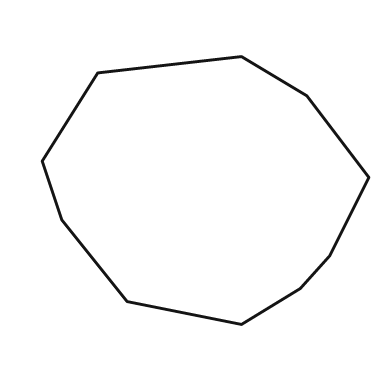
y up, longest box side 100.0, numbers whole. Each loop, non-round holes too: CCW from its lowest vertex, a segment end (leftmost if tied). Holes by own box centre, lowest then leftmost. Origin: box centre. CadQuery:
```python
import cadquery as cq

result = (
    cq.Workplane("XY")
    .moveTo(11.0, -41.0)
    .lineTo(29.0, -30.0)
    .lineTo(38.0, -20.0)
    .lineTo(50.0, 4.0)
    .lineTo(31.0, 29.0)
    .lineTo(11.0, 41.0)
    .lineTo(-33.0, 36.0)
    .lineTo(-50.0, 9.0)
    .lineTo(-44.0, -9.0)
    .lineTo(-24.0, -34.0)
    .close()
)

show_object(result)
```